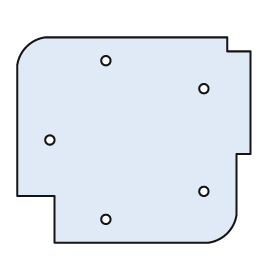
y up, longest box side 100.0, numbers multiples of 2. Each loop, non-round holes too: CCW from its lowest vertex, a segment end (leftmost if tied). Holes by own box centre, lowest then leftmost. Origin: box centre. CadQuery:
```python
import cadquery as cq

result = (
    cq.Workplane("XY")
    .moveTo(-34.0, -44.0)
    .lineTo(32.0, -44.0)
    .threePointArc((40.0, -40.0), (44.0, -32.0))
    .lineTo(44.0, -6.0)
    .lineTo(50.0, -6.0)
    .lineTo(50.0, 38.0)
    .lineTo(40.0, 38.0)
    .lineTo(40.0, 44.0)
    .lineTo(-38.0, 44.0)
    .threePointArc((-46.0, 40.0), (-50.0, 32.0))
    .lineTo(-50.0, -24.0)
    .lineTo(-34.0, -24.0)
    .close()
    .moveTo(-12.0, -34.0)
    .circle(2.0)
    .moveTo(30.0, -22.0)
    .circle(2.0)
    .moveTo(-36.0, 0.0)
    .circle(2.0)
    .moveTo(30.0, 22.0)
    .circle(2.0)
    .moveTo(-12.0, 34.0)
    .circle(2.0)
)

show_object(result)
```